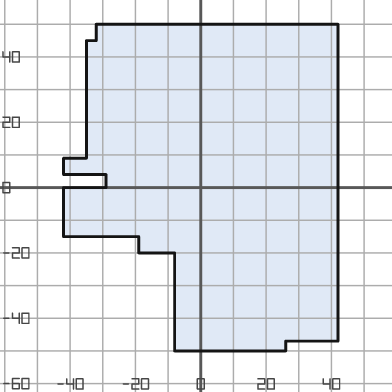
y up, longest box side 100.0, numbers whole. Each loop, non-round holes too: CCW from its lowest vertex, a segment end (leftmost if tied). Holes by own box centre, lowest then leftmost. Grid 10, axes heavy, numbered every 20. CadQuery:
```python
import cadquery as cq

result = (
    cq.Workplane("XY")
    .moveTo(-8.0, -50.0)
    .lineTo(26.0, -50.0)
    .lineTo(26.0, -47.0)
    .lineTo(42.0, -47.0)
    .lineTo(42.0, 50.0)
    .lineTo(-32.0, 50.0)
    .lineTo(-32.0, 45.0)
    .lineTo(-35.0, 45.0)
    .lineTo(-35.0, 9.0)
    .lineTo(-42.0, 9.0)
    .lineTo(-42.0, 4.0)
    .lineTo(-29.0, 4.0)
    .lineTo(-29.0, 0.0)
    .lineTo(-42.0, 0.0)
    .lineTo(-42.0, -15.0)
    .lineTo(-19.0, -15.0)
    .lineTo(-19.0, -20.0)
    .lineTo(-8.0, -20.0)
    .close()
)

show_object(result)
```